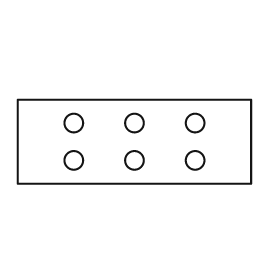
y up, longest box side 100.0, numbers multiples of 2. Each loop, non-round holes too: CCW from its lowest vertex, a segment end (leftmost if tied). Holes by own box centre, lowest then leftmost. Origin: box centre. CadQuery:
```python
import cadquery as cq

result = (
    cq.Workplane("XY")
    .moveTo(-50.0, -18.0)
    .lineTo(50.0, -18.0)
    .lineTo(50.0, 18.0)
    .lineTo(-50.0, 18.0)
    .close()
    .moveTo(-26.0, -8.0)
    .circle(4.0)
    .moveTo(0.0, -8.0)
    .circle(4.0)
    .moveTo(26.0, -8.0)
    .circle(4.0)
    .moveTo(-26.0, 8.0)
    .circle(4.0)
    .moveTo(0.0, 8.0)
    .circle(4.0)
    .moveTo(26.0, 8.0)
    .circle(4.0)
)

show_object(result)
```